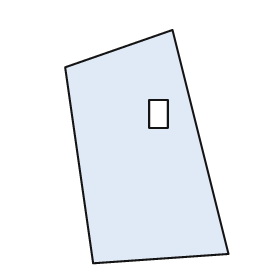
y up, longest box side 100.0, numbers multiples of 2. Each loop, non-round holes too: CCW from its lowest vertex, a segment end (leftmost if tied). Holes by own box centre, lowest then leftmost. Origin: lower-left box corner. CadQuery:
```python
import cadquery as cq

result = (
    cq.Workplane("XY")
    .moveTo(12.0, 0.0)
    .lineTo(70.0, 4.0)
    .lineTo(46.0, 100.0)
    .lineTo(0.0, 84.0)
    .close()
    .moveTo(36.0, 58.0)
    .lineTo(44.0, 58.0)
    .lineTo(44.0, 70.0)
    .lineTo(36.0, 70.0)
    .close()
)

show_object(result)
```